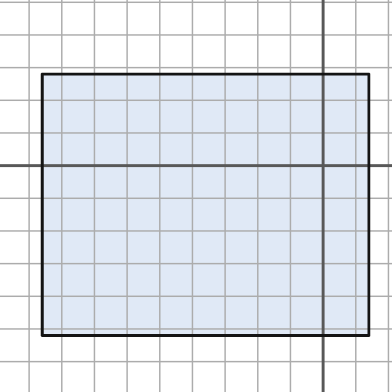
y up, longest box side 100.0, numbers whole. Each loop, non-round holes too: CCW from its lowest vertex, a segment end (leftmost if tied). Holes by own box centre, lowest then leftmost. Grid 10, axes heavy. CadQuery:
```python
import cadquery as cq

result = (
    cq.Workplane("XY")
    .moveTo(-86.0, -52.0)
    .lineTo(14.0, -52.0)
    .lineTo(14.0, 28.0)
    .lineTo(-86.0, 28.0)
    .close()
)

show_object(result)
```